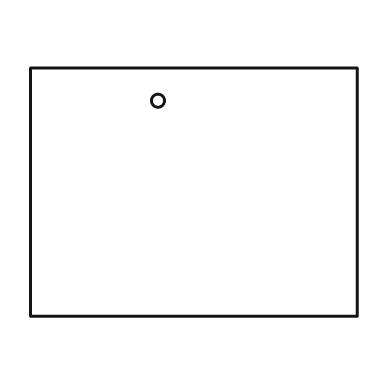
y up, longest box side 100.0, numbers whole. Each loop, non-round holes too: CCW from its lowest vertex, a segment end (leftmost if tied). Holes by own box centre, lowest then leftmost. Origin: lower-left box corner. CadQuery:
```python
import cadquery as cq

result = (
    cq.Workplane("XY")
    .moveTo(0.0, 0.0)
    .lineTo(100.0, 0.0)
    .lineTo(100.0, 76.0)
    .lineTo(0.0, 76.0)
    .close()
    .moveTo(39.0, 66.0)
    .circle(2.0)
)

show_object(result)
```